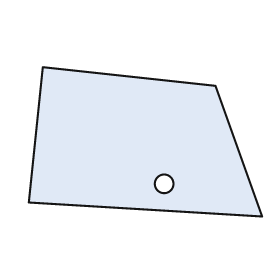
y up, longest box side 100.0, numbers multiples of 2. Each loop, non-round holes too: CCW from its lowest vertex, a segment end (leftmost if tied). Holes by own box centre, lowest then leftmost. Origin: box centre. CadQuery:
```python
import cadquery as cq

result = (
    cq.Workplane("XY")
    .moveTo(50.0, -32.0)
    .lineTo(30.0, 24.0)
    .lineTo(-44.0, 32.0)
    .lineTo(-50.0, -26.0)
    .close()
    .moveTo(8.0, -18.0)
    .circle(4.0)
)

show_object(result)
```